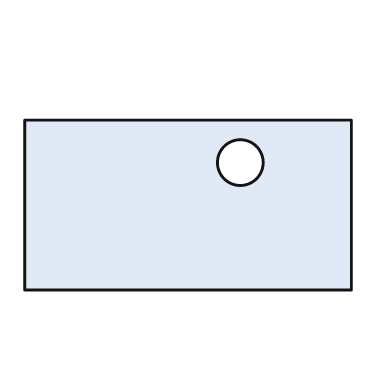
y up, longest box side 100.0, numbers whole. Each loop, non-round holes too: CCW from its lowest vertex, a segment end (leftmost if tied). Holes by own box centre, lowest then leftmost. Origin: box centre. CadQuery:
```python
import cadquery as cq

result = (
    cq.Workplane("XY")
    .moveTo(-50.0, -26.0)
    .lineTo(50.0, -26.0)
    .lineTo(50.0, 26.0)
    .lineTo(-50.0, 26.0)
    .close()
    .moveTo(16.0, 13.0)
    .circle(7.0)
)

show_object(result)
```